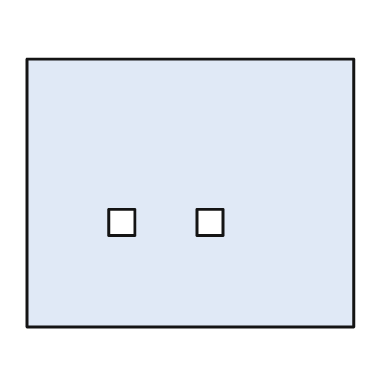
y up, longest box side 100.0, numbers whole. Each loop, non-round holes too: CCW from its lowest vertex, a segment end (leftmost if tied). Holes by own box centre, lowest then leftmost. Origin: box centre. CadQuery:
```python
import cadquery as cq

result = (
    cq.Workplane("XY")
    .moveTo(-50.0, -41.0)
    .lineTo(50.0, -41.0)
    .lineTo(50.0, 41.0)
    .lineTo(-50.0, 41.0)
    .close()
    .moveTo(-25.0, -13.0)
    .lineTo(-17.0, -13.0)
    .lineTo(-17.0, -5.0)
    .lineTo(-25.0, -5.0)
    .close()
    .moveTo(2.0, -13.0)
    .lineTo(10.0, -13.0)
    .lineTo(10.0, -5.0)
    .lineTo(2.0, -5.0)
    .close()
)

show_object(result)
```